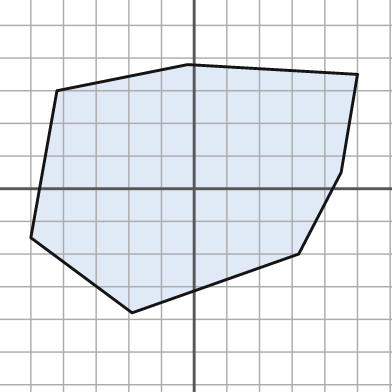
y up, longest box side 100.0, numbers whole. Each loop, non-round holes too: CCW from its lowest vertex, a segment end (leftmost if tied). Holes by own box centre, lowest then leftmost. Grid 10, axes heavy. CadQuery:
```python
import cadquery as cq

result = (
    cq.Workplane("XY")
    .moveTo(-19.0, -38.0)
    .lineTo(32.0, -20.0)
    .lineTo(45.0, 5.0)
    .lineTo(50.0, 35.0)
    .lineTo(-2.0, 38.0)
    .lineTo(-42.0, 30.0)
    .lineTo(-50.0, -15.0)
    .close()
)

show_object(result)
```